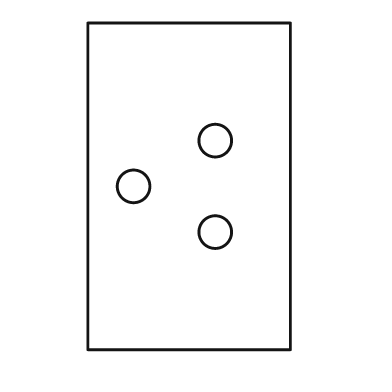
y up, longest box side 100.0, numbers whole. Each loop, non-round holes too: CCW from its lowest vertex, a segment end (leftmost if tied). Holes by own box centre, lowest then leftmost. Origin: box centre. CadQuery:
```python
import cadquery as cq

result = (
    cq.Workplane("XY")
    .moveTo(-31.0, -50.0)
    .lineTo(31.0, -50.0)
    .lineTo(31.0, 50.0)
    .lineTo(-31.0, 50.0)
    .close()
    .moveTo(8.0, -14.0)
    .circle(5.0)
    .moveTo(-17.0, 0.0)
    .circle(5.0)
    .moveTo(8.0, 14.0)
    .circle(5.0)
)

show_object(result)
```